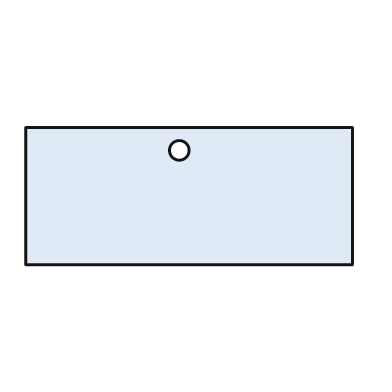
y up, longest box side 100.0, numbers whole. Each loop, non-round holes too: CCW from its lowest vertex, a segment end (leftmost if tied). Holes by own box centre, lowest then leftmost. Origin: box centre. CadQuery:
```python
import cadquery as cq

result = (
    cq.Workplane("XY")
    .moveTo(-50.0, -21.0)
    .lineTo(50.0, -21.0)
    .lineTo(50.0, 21.0)
    .lineTo(-50.0, 21.0)
    .close()
    .moveTo(-3.0, 14.0)
    .circle(3.0)
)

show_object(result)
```